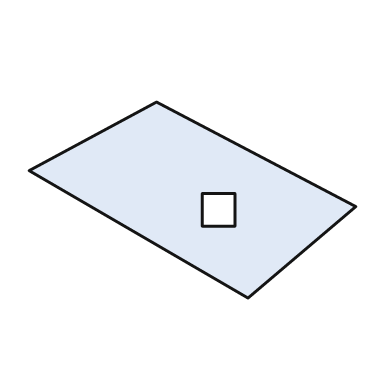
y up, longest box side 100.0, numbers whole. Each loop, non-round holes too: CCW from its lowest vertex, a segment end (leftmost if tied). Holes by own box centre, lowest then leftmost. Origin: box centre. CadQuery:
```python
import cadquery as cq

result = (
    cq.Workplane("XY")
    .moveTo(17.0, -30.0)
    .lineTo(50.0, -2.0)
    .lineTo(-11.0, 30.0)
    .lineTo(-50.0, 9.0)
    .close()
    .moveTo(3.0, -8.0)
    .lineTo(13.0, -8.0)
    .lineTo(13.0, 2.0)
    .lineTo(3.0, 2.0)
    .close()
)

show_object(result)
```